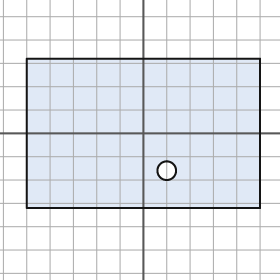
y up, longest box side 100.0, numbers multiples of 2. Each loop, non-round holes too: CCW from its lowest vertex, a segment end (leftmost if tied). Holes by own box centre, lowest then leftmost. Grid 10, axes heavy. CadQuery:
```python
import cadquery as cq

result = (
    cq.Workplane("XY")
    .moveTo(-50.0, -32.0)
    .lineTo(50.0, -32.0)
    .lineTo(50.0, 32.0)
    .lineTo(-50.0, 32.0)
    .close()
    .moveTo(10.0, -16.0)
    .circle(4.0)
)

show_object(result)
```